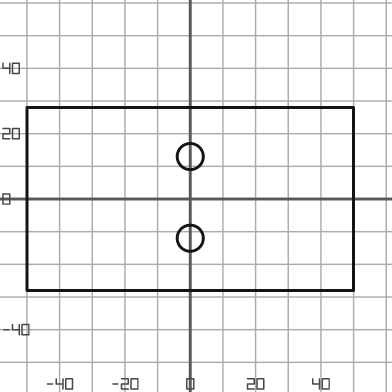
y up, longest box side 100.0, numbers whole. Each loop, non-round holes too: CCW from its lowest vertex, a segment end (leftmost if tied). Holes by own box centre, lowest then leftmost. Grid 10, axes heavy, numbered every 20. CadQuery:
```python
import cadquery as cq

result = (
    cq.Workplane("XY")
    .moveTo(-50.0, -28.0)
    .lineTo(50.0, -28.0)
    .lineTo(50.0, 28.0)
    .lineTo(-50.0, 28.0)
    .close()
    .moveTo(0.0, -12.0)
    .circle(4.0)
    .moveTo(0.0, 13.0)
    .circle(4.0)
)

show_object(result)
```